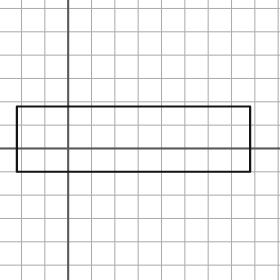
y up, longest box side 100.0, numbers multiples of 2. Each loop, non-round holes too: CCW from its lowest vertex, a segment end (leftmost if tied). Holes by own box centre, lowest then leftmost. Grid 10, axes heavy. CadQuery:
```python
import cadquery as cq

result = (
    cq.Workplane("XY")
    .moveTo(-22.0, -10.0)
    .lineTo(78.0, -10.0)
    .lineTo(78.0, 18.0)
    .lineTo(-22.0, 18.0)
    .close()
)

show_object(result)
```